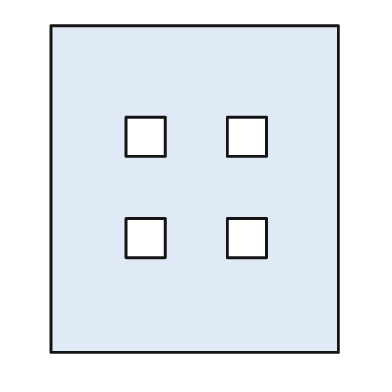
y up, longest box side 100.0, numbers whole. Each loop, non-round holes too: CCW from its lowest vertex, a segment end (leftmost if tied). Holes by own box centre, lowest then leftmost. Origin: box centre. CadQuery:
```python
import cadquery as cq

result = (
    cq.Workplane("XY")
    .moveTo(-44.0, -50.0)
    .lineTo(44.0, -50.0)
    .lineTo(44.0, 50.0)
    .lineTo(-44.0, 50.0)
    .close()
    .moveTo(-21.0, -21.0)
    .lineTo(-9.0, -21.0)
    .lineTo(-9.0, -9.0)
    .lineTo(-21.0, -9.0)
    .close()
    .moveTo(10.0, -21.0)
    .lineTo(22.0, -21.0)
    .lineTo(22.0, -9.0)
    .lineTo(10.0, -9.0)
    .close()
    .moveTo(-21.0, 10.0)
    .lineTo(-9.0, 10.0)
    .lineTo(-9.0, 22.0)
    .lineTo(-21.0, 22.0)
    .close()
    .moveTo(10.0, 10.0)
    .lineTo(22.0, 10.0)
    .lineTo(22.0, 22.0)
    .lineTo(10.0, 22.0)
    .close()
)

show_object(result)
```